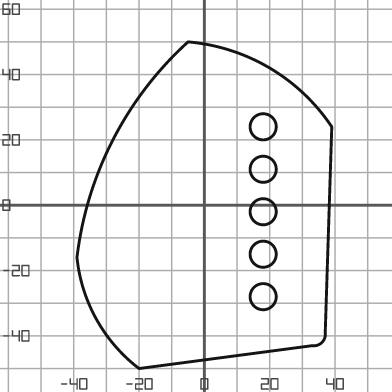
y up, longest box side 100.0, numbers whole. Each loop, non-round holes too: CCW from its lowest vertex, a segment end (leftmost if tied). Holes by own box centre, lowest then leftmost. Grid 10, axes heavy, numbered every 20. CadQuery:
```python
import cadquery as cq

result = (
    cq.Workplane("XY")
    .moveTo(-20.0, -50.0)
    .lineTo(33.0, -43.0)
    .threePointArc((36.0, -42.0), (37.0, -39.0))
    .lineTo(39.0, 24.0)
    .threePointArc((20.0, 42.0), (-5.0, 50.0))
    .threePointArc((-28.0, 20.0), (-39.0, -16.0))
    .threePointArc((-33.0, -35.0), (-20.0, -50.0))
    .close()
    .moveTo(18.0, -28.0)
    .circle(4.0)
    .moveTo(18.0, -15.0)
    .circle(4.0)
    .moveTo(18.0, -2.0)
    .circle(4.0)
    .moveTo(18.0, 11.0)
    .circle(4.0)
    .moveTo(18.0, 24.0)
    .circle(4.0)
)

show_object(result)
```